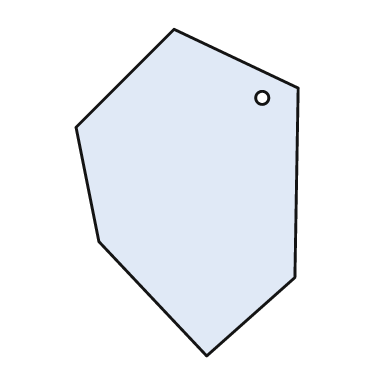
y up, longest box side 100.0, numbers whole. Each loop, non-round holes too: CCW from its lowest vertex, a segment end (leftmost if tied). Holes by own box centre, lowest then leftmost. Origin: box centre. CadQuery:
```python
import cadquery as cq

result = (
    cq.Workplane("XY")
    .moveTo(6.0, -50.0)
    .lineTo(33.0, -26.0)
    .lineTo(34.0, 32.0)
    .lineTo(-4.0, 50.0)
    .lineTo(-34.0, 20.0)
    .lineTo(-27.0, -15.0)
    .close()
    .moveTo(23.0, 29.0)
    .circle(2.0)
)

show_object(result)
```